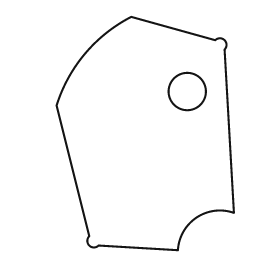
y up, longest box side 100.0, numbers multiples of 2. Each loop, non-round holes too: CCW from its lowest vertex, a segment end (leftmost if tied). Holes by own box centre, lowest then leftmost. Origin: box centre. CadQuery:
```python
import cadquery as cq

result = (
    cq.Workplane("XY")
    .moveTo(14.0, -50.0)
    .threePointArc((22.0, -36.0), (38.0, -34.0))
    .lineTo(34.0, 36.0)
    .threePointArc((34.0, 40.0), (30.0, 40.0))
    .lineTo(-6.0, 50.0)
    .threePointArc((-26.0, 34.0), (-38.0, 12.0))
    .lineTo(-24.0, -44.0)
    .threePointArc((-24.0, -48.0), (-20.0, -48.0))
    .close()
    .moveTo(18.0, 18.0)
    .circle(8.0)
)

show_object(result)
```